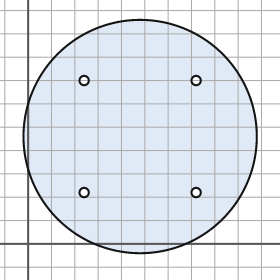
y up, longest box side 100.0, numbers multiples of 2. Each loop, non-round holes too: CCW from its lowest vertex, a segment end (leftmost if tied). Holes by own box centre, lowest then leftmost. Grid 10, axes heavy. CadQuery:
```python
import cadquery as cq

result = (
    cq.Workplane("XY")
    .moveTo(48.0, 46.0)
    .circle(50.0)
    .moveTo(24.0, 22.0)
    .circle(2.0)
    .moveTo(72.0, 22.0)
    .circle(2.0)
    .moveTo(24.0, 70.0)
    .circle(2.0)
    .moveTo(72.0, 70.0)
    .circle(2.0)
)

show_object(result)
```